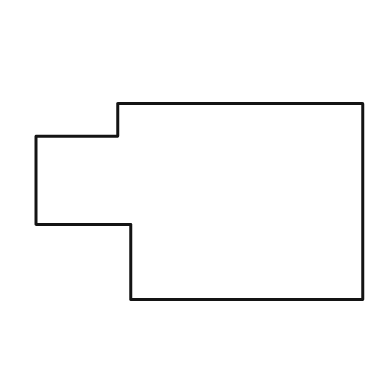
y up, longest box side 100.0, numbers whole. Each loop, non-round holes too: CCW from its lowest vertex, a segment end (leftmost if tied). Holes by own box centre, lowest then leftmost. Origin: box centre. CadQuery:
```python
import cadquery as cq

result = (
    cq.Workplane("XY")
    .moveTo(-21.0, -30.0)
    .lineTo(50.0, -30.0)
    .lineTo(50.0, 30.0)
    .lineTo(-25.0, 30.0)
    .lineTo(-25.0, 20.0)
    .lineTo(-50.0, 20.0)
    .lineTo(-50.0, -7.0)
    .lineTo(-21.0, -7.0)
    .close()
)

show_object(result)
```